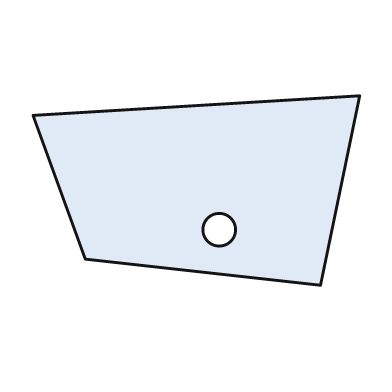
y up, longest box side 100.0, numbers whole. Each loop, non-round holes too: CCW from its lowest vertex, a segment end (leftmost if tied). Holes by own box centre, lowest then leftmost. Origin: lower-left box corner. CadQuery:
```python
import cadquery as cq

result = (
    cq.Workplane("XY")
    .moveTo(88.0, 0.0)
    .lineTo(100.0, 58.0)
    .lineTo(0.0, 52.0)
    .lineTo(16.0, 8.0)
    .close()
    .moveTo(57.0, 17.0)
    .circle(5.0)
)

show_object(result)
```